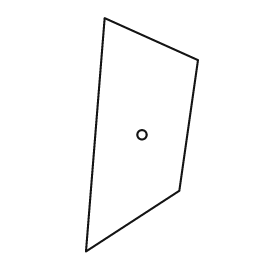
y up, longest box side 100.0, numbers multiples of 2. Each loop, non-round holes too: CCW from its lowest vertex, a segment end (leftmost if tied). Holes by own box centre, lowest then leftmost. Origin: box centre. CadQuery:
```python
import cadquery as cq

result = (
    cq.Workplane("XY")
    .moveTo(-24.0, -50.0)
    .lineTo(16.0, -24.0)
    .lineTo(24.0, 32.0)
    .lineTo(-16.0, 50.0)
    .close()
    .moveTo(0.0, 0.0)
    .circle(2.0)
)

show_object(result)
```